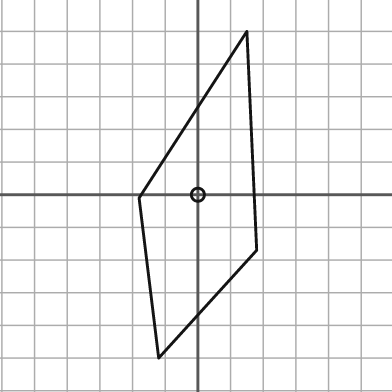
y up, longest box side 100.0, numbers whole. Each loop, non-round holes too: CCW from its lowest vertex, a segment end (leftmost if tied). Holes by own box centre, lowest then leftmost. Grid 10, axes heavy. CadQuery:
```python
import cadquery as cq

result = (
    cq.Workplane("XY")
    .moveTo(-12.0, -50.0)
    .lineTo(18.0, -17.0)
    .lineTo(15.0, 50.0)
    .lineTo(-18.0, -1.0)
    .close()
    .moveTo(0.0, 0.0)
    .circle(2.0)
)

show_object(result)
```